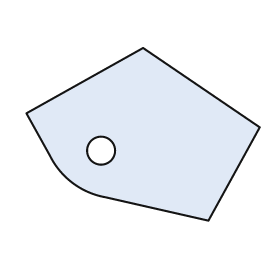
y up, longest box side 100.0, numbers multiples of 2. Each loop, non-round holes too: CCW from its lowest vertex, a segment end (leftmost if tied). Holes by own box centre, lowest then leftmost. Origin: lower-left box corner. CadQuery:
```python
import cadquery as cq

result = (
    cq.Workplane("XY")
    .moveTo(78.0, 0.0)
    .lineTo(100.0, 40.0)
    .lineTo(50.0, 74.0)
    .lineTo(0.0, 46.0)
    .lineTo(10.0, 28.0)
    .threePointArc((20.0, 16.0), (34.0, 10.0))
    .close()
    .moveTo(32.0, 30.0)
    .circle(6.0)
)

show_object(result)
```